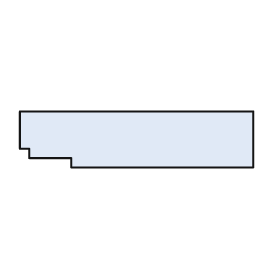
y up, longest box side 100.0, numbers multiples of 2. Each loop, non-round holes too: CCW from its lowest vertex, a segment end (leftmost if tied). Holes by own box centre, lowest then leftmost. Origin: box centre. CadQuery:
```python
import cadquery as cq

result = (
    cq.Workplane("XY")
    .moveTo(-28.0, -12.0)
    .lineTo(50.0, -12.0)
    .lineTo(50.0, 12.0)
    .lineTo(-50.0, 12.0)
    .lineTo(-50.0, -4.0)
    .lineTo(-46.0, -4.0)
    .lineTo(-46.0, -8.0)
    .lineTo(-28.0, -8.0)
    .close()
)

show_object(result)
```